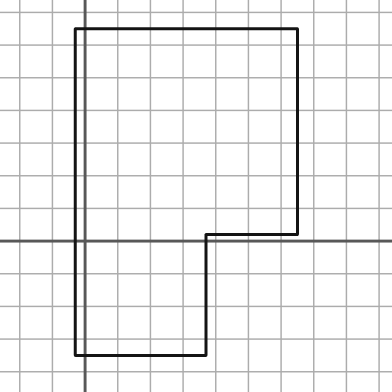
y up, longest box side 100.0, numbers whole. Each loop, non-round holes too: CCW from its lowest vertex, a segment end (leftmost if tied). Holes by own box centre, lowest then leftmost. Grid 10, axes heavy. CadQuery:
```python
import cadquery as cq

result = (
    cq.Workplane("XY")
    .moveTo(-3.0, -35.0)
    .lineTo(37.0, -35.0)
    .lineTo(37.0, 2.0)
    .lineTo(65.0, 2.0)
    .lineTo(65.0, 65.0)
    .lineTo(-3.0, 65.0)
    .close()
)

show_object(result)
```